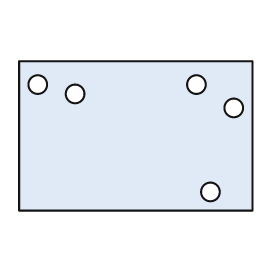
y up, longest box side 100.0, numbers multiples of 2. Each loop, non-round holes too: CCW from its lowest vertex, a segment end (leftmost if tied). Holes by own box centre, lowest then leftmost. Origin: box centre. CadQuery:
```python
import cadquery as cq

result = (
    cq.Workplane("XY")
    .moveTo(-50.0, -32.0)
    .lineTo(50.0, -32.0)
    .lineTo(50.0, 32.0)
    .lineTo(-50.0, 32.0)
    .close()
    .moveTo(32.0, -24.0)
    .circle(4.0)
    .moveTo(42.0, 12.0)
    .circle(4.0)
    .moveTo(-26.0, 18.0)
    .circle(4.0)
    .moveTo(-42.0, 22.0)
    .circle(4.0)
    .moveTo(26.0, 22.0)
    .circle(4.0)
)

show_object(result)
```